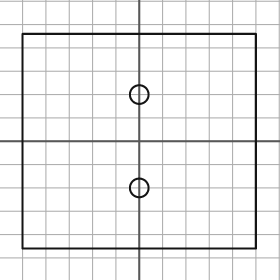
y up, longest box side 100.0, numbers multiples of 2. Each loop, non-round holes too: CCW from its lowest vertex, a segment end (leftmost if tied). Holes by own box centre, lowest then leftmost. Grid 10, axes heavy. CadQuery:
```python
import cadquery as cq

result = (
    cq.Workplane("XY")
    .moveTo(-50.0, -46.0)
    .lineTo(50.0, -46.0)
    .lineTo(50.0, 46.0)
    .lineTo(-50.0, 46.0)
    .close()
    .moveTo(0.0, -20.0)
    .circle(4.0)
    .moveTo(0.0, 20.0)
    .circle(4.0)
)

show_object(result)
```